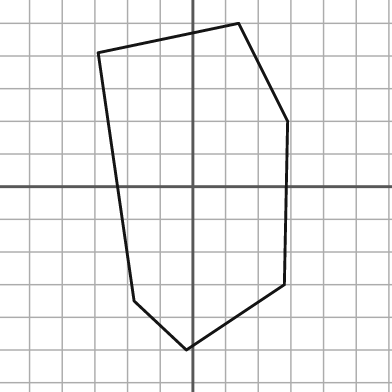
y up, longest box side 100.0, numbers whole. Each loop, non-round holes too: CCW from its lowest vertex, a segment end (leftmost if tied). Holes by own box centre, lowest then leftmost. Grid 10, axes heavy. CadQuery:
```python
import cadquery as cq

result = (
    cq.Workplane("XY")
    .moveTo(-2.0, -50.0)
    .lineTo(28.0, -30.0)
    .lineTo(29.0, 20.0)
    .lineTo(14.0, 50.0)
    .lineTo(-29.0, 41.0)
    .lineTo(-18.0, -35.0)
    .close()
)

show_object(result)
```